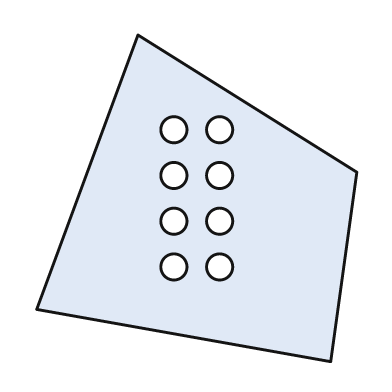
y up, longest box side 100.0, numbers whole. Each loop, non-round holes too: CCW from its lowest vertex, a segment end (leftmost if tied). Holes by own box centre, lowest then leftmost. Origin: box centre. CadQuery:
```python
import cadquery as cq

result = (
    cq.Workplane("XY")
    .moveTo(41.0, -50.0)
    .lineTo(49.0, 8.0)
    .lineTo(-18.0, 50.0)
    .lineTo(-49.0, -34.0)
    .close()
    .moveTo(-7.0, -21.0)
    .circle(4.0)
    .moveTo(7.0, -21.0)
    .circle(4.0)
    .moveTo(-7.0, -7.0)
    .circle(4.0)
    .moveTo(7.0, -7.0)
    .circle(4.0)
    .moveTo(-7.0, 7.0)
    .circle(4.0)
    .moveTo(7.0, 7.0)
    .circle(4.0)
    .moveTo(-7.0, 21.0)
    .circle(4.0)
    .moveTo(7.0, 21.0)
    .circle(4.0)
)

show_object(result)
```